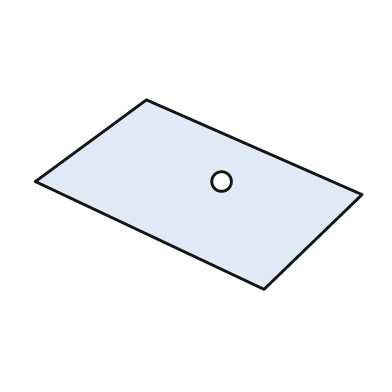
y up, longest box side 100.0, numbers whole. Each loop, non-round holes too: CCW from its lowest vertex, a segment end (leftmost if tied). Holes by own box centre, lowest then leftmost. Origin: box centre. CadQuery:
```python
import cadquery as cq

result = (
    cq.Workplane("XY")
    .moveTo(20.0, -29.0)
    .lineTo(50.0, 0.0)
    .lineTo(-16.0, 29.0)
    .lineTo(-50.0, 4.0)
    .close()
    .moveTo(7.0, 4.0)
    .circle(3.0)
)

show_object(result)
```